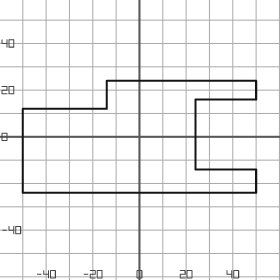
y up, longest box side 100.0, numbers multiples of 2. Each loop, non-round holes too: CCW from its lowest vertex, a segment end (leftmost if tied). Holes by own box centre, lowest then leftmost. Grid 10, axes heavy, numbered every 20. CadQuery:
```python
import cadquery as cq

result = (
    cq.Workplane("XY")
    .moveTo(-50.0, -24.0)
    .lineTo(50.0, -24.0)
    .lineTo(50.0, -14.0)
    .lineTo(24.0, -14.0)
    .lineTo(24.0, 16.0)
    .lineTo(50.0, 16.0)
    .lineTo(50.0, 24.0)
    .lineTo(-14.0, 24.0)
    .lineTo(-14.0, 12.0)
    .lineTo(-50.0, 12.0)
    .close()
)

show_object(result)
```